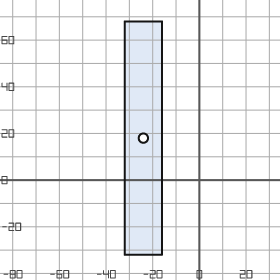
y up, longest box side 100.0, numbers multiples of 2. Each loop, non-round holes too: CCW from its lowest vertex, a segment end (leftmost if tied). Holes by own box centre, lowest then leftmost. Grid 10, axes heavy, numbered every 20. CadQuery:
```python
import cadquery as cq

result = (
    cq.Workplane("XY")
    .moveTo(-32.0, -32.0)
    .lineTo(-16.0, -32.0)
    .lineTo(-16.0, 68.0)
    .lineTo(-32.0, 68.0)
    .close()
    .moveTo(-24.0, 18.0)
    .circle(2.0)
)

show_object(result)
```